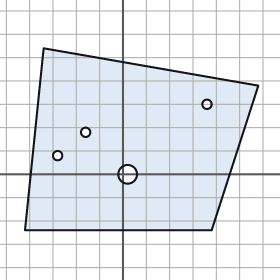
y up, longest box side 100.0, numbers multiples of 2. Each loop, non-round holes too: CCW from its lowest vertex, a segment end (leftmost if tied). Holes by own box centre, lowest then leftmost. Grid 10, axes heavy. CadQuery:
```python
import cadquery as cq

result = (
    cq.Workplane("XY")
    .moveTo(-42.0, -24.0)
    .lineTo(38.0, -24.0)
    .lineTo(58.0, 38.0)
    .lineTo(-34.0, 54.0)
    .close()
    .moveTo(2.0, 0.0)
    .circle(4.0)
    .moveTo(-28.0, 8.0)
    .circle(2.0)
    .moveTo(-16.0, 18.0)
    .circle(2.0)
    .moveTo(36.0, 30.0)
    .circle(2.0)
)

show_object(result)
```